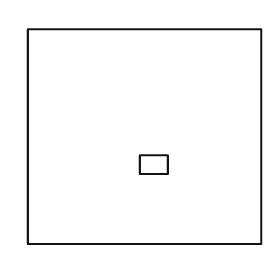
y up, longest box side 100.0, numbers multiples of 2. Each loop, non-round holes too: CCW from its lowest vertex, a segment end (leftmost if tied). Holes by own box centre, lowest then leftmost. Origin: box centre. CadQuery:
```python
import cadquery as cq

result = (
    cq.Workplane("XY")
    .moveTo(-50.0, -46.0)
    .lineTo(50.0, -46.0)
    .lineTo(50.0, 46.0)
    .lineTo(-50.0, 46.0)
    .close()
    .moveTo(-2.0, -16.0)
    .lineTo(10.0, -16.0)
    .lineTo(10.0, -8.0)
    .lineTo(-2.0, -8.0)
    .close()
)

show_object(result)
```